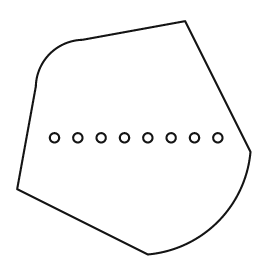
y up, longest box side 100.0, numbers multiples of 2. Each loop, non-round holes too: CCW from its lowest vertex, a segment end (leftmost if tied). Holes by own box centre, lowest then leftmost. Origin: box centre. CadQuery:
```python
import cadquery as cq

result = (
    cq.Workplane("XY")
    .moveTo(6.0, -50.0)
    .threePointArc((36.0, -36.0), (50.0, -6.0))
    .lineTo(22.0, 50.0)
    .lineTo(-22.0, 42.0)
    .threePointArc((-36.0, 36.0), (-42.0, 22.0))
    .lineTo(-50.0, -22.0)
    .close()
    .moveTo(-34.0, 0.0)
    .circle(2.0)
    .moveTo(-24.0, 0.0)
    .circle(2.0)
    .moveTo(-14.0, 0.0)
    .circle(2.0)
    .moveTo(-4.0, 0.0)
    .circle(2.0)
    .moveTo(6.0, 0.0)
    .circle(2.0)
    .moveTo(16.0, 0.0)
    .circle(2.0)
    .moveTo(26.0, 0.0)
    .circle(2.0)
    .moveTo(36.0, 0.0)
    .circle(2.0)
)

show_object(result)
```